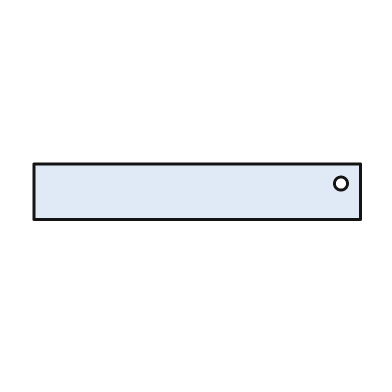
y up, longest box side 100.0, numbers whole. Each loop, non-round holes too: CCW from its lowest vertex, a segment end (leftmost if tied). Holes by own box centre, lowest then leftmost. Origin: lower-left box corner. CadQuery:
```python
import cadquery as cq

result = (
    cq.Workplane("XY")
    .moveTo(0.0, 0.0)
    .lineTo(100.0, 0.0)
    .lineTo(100.0, 17.0)
    .lineTo(0.0, 17.0)
    .close()
    .moveTo(94.0, 11.0)
    .circle(2.0)
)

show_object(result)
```